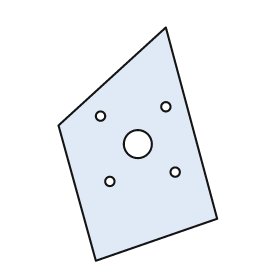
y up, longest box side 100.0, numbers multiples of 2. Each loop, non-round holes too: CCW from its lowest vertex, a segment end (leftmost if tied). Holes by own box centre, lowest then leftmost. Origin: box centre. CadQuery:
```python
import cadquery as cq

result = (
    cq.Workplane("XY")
    .moveTo(-18.0, -50.0)
    .lineTo(34.0, -32.0)
    .lineTo(12.0, 50.0)
    .lineTo(-34.0, 8.0)
    .close()
    .moveTo(-12.0, -16.0)
    .circle(2.0)
    .moveTo(16.0, -12.0)
    .circle(2.0)
    .moveTo(0.0, 0.0)
    .circle(6.0)
    .moveTo(-16.0, 12.0)
    .circle(2.0)
    .moveTo(12.0, 16.0)
    .circle(2.0)
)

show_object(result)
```